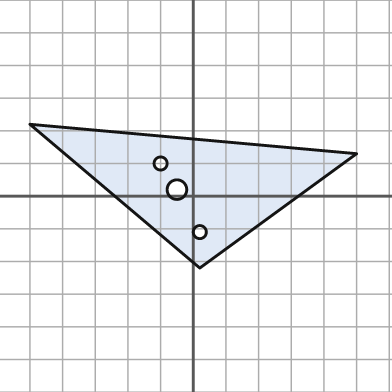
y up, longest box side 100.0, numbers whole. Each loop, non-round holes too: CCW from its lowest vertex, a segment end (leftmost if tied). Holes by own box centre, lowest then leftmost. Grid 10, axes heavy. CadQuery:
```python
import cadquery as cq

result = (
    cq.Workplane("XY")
    .moveTo(2.0, -22.0)
    .lineTo(50.0, 13.0)
    .lineTo(-50.0, 22.0)
    .close()
    .moveTo(2.0, -11.0)
    .circle(2.0)
    .moveTo(-5.0, 2.0)
    .circle(3.0)
    .moveTo(-10.0, 10.0)
    .circle(2.0)
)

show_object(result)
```